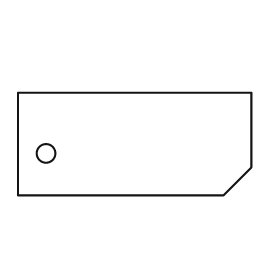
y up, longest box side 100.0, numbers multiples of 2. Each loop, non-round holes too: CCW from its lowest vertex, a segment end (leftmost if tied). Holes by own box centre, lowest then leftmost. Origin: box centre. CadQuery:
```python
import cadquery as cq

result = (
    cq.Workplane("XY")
    .moveTo(-50.0, -22.0)
    .lineTo(38.0, -22.0)
    .lineTo(50.0, -10.0)
    .lineTo(50.0, 22.0)
    .lineTo(-50.0, 22.0)
    .close()
    .moveTo(-38.0, -4.0)
    .circle(4.0)
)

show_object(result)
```